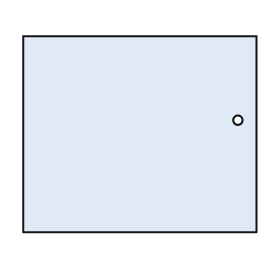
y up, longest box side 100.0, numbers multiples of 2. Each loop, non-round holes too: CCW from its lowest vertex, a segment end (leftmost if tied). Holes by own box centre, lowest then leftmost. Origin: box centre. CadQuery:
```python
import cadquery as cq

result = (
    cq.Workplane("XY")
    .moveTo(-50.0, -42.0)
    .lineTo(50.0, -42.0)
    .lineTo(50.0, 42.0)
    .lineTo(-50.0, 42.0)
    .close()
    .moveTo(42.0, 6.0)
    .circle(2.0)
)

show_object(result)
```